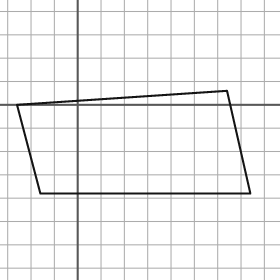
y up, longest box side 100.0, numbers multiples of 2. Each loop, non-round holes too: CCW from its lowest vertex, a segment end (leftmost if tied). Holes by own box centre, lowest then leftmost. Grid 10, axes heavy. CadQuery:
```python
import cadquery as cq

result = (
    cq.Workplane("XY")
    .moveTo(-16.0, -38.0)
    .lineTo(74.0, -38.0)
    .lineTo(64.0, 6.0)
    .lineTo(-26.0, 0.0)
    .close()
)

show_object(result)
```